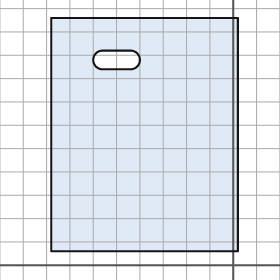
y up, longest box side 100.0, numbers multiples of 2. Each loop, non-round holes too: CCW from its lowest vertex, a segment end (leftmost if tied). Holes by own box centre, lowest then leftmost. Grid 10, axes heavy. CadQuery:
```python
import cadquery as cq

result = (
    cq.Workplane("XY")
    .moveTo(-78.0, 6.0)
    .lineTo(2.0, 6.0)
    .lineTo(2.0, 106.0)
    .lineTo(-78.0, 106.0)
    .close()
    .moveTo(-56.0, 84.0)
    .lineTo(-44.0, 84.0)
    .threePointArc((-40.0, 88.0), (-44.0, 92.0))
    .lineTo(-56.0, 92.0)
    .threePointArc((-60.0, 88.0), (-56.0, 84.0))
    .close()
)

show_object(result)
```